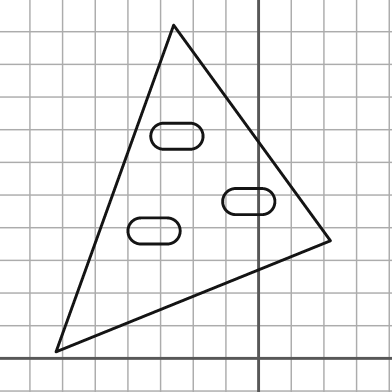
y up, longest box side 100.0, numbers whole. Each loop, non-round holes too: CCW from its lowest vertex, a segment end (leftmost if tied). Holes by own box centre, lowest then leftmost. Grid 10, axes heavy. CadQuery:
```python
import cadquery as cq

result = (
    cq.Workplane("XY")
    .moveTo(-62.0, 2.0)
    .lineTo(22.0, 36.0)
    .lineTo(-26.0, 102.0)
    .close()
    .moveTo(-36.0, 35.0)
    .lineTo(-28.0, 35.0)
    .threePointArc((-24.0, 39.0), (-28.0, 43.0))
    .lineTo(-36.0, 43.0)
    .threePointArc((-40.0, 39.0), (-36.0, 35.0))
    .close()
    .moveTo(-7.0, 44.0)
    .lineTo(1.0, 44.0)
    .threePointArc((5.0, 48.0), (1.0, 52.0))
    .lineTo(-7.0, 52.0)
    .threePointArc((-11.0, 48.0), (-7.0, 44.0))
    .close()
    .moveTo(-29.0, 64.0)
    .lineTo(-21.0, 64.0)
    .threePointArc((-17.0, 68.0), (-21.0, 72.0))
    .lineTo(-29.0, 72.0)
    .threePointArc((-33.0, 68.0), (-29.0, 64.0))
    .close()
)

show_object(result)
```